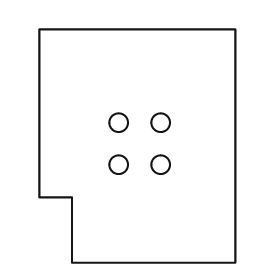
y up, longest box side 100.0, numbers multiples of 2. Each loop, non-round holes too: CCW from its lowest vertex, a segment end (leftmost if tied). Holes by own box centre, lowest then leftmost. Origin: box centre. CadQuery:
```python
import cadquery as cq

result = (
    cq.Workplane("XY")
    .moveTo(-28.0, -50.0)
    .lineTo(42.0, -50.0)
    .lineTo(42.0, 50.0)
    .lineTo(-42.0, 50.0)
    .lineTo(-42.0, -22.0)
    .lineTo(-28.0, -22.0)
    .close()
    .moveTo(-8.0, -8.0)
    .circle(4.0)
    .moveTo(10.0, -8.0)
    .circle(4.0)
    .moveTo(-8.0, 10.0)
    .circle(4.0)
    .moveTo(10.0, 10.0)
    .circle(4.0)
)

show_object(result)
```